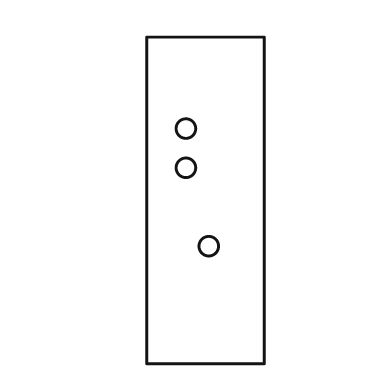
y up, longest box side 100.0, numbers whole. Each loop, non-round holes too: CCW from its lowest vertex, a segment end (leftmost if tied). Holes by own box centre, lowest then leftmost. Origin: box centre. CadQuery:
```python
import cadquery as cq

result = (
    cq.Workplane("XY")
    .moveTo(-18.0, -50.0)
    .lineTo(18.0, -50.0)
    .lineTo(18.0, 50.0)
    .lineTo(-18.0, 50.0)
    .close()
    .moveTo(1.0, -14.0)
    .circle(3.0)
    .moveTo(-6.0, 10.0)
    .circle(3.0)
    .moveTo(-6.0, 22.0)
    .circle(3.0)
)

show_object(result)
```